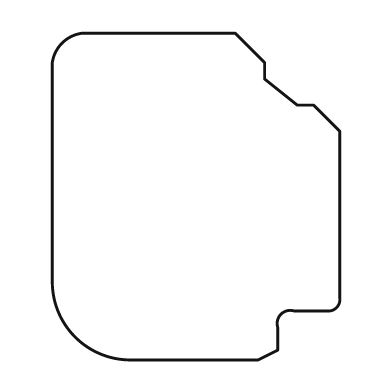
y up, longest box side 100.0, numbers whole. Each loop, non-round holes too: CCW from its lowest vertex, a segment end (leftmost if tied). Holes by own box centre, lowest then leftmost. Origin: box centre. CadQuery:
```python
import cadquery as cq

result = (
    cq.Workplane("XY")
    .moveTo(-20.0, -50.0)
    .lineTo(19.0, -50.0)
    .lineTo(25.0, -47.0)
    .lineTo(25.0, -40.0)
    .threePointArc((26.0, -36.0), (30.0, -35.0))
    .lineTo(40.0, -35.0)
    .threePointArc((43.0, -34.0), (44.0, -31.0))
    .lineTo(44.0, 20.0)
    .lineTo(36.0, 28.0)
    .lineTo(31.0, 28.0)
    .lineTo(21.0, 36.0)
    .lineTo(21.0, 41.0)
    .lineTo(12.0, 50.0)
    .lineTo(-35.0, 50.0)
    .threePointArc((-41.0, 47.0), (-44.0, 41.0))
    .lineTo(-44.0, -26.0)
    .threePointArc((-37.0, -43.0), (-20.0, -50.0))
    .close()
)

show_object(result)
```